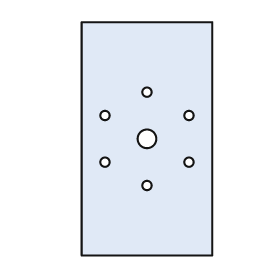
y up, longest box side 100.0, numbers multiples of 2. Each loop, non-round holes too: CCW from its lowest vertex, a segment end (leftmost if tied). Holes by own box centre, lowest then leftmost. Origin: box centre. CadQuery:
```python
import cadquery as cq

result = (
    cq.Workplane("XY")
    .moveTo(-28.0, -50.0)
    .lineTo(28.0, -50.0)
    .lineTo(28.0, 50.0)
    .lineTo(-28.0, 50.0)
    .close()
    .moveTo(0.0, -20.0)
    .circle(2.0)
    .moveTo(-18.0, -10.0)
    .circle(2.0)
    .moveTo(18.0, -10.0)
    .circle(2.0)
    .moveTo(0.0, 0.0)
    .circle(4.0)
    .moveTo(-18.0, 10.0)
    .circle(2.0)
    .moveTo(18.0, 10.0)
    .circle(2.0)
    .moveTo(0.0, 20.0)
    .circle(2.0)
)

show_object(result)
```